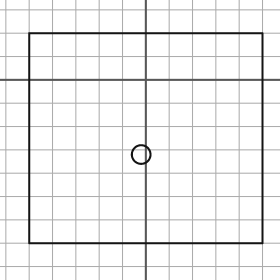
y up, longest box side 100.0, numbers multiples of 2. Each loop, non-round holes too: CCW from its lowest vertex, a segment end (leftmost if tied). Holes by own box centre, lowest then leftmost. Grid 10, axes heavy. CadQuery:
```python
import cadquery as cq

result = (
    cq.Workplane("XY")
    .moveTo(-50.0, -70.0)
    .lineTo(50.0, -70.0)
    .lineTo(50.0, 20.0)
    .lineTo(-50.0, 20.0)
    .close()
    .moveTo(-2.0, -32.0)
    .circle(4.0)
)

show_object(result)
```